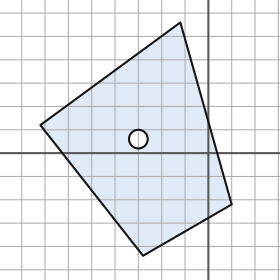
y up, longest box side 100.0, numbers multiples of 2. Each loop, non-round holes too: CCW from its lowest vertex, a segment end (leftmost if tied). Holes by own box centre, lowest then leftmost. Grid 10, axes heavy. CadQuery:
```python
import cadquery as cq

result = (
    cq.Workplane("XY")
    .moveTo(-28.0, -44.0)
    .lineTo(10.0, -22.0)
    .lineTo(-12.0, 56.0)
    .lineTo(-72.0, 12.0)
    .close()
    .moveTo(-30.0, 6.0)
    .circle(4.0)
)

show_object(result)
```